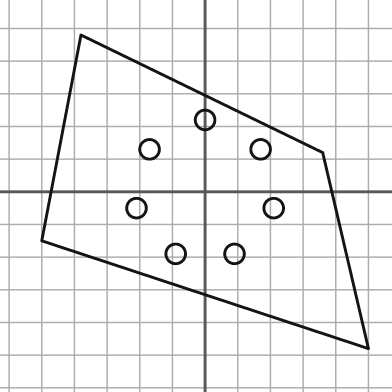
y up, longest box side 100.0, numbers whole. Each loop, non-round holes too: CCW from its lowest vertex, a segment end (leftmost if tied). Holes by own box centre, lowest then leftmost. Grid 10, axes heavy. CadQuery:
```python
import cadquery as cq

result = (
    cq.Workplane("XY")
    .moveTo(50.0, -48.0)
    .lineTo(36.0, 12.0)
    .lineTo(-38.0, 48.0)
    .lineTo(-50.0, -15.0)
    .close()
    .moveTo(-9.0, -19.0)
    .circle(3.0)
    .moveTo(9.0, -19.0)
    .circle(3.0)
    .moveTo(-21.0, -5.0)
    .circle(3.0)
    .moveTo(21.0, -5.0)
    .circle(3.0)
    .moveTo(-17.0, 13.0)
    .circle(3.0)
    .moveTo(17.0, 13.0)
    .circle(3.0)
    .moveTo(0.0, 22.0)
    .circle(3.0)
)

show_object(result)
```